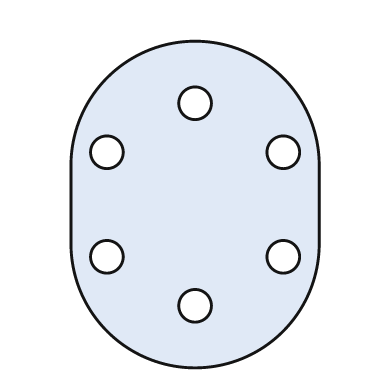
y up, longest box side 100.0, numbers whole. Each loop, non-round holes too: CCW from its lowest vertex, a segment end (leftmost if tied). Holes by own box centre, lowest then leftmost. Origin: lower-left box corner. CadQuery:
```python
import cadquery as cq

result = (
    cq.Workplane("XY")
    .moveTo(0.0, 38.0)
    .threePointArc((38.0, 0.0), (76.0, 38.0))
    .lineTo(76.0, 62.0)
    .threePointArc((38.0, 100.0), (0.0, 62.0))
    .close()
    .moveTo(38.0, 19.0)
    .circle(5.0)
    .moveTo(11.0, 34.0)
    .circle(5.0)
    .moveTo(65.0, 34.0)
    .circle(5.0)
    .moveTo(11.0, 66.0)
    .circle(5.0)
    .moveTo(65.0, 66.0)
    .circle(5.0)
    .moveTo(38.0, 81.0)
    .circle(5.0)
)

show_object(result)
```